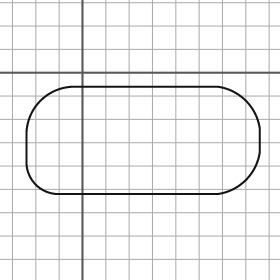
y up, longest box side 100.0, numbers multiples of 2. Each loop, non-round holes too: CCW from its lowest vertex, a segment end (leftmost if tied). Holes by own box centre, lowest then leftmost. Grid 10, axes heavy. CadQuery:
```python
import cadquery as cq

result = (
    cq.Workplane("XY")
    .moveTo(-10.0, -52.0)
    .lineTo(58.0, -52.0)
    .threePointArc((70.0, -46.0), (76.0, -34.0))
    .lineTo(76.0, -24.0)
    .threePointArc((70.0, -12.0), (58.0, -6.0))
    .lineTo(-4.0, -6.0)
    .threePointArc((-18.0, -12.0), (-24.0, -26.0))
    .lineTo(-24.0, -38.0)
    .threePointArc((-20.0, -48.0), (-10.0, -52.0))
    .close()
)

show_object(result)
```